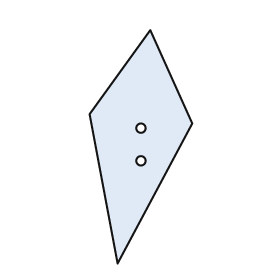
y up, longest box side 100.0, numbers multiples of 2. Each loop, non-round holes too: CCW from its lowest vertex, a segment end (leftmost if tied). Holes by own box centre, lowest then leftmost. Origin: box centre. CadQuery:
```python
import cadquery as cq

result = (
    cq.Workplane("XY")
    .moveTo(-10.0, -50.0)
    .lineTo(22.0, 10.0)
    .lineTo(4.0, 50.0)
    .lineTo(-22.0, 14.0)
    .close()
    .moveTo(0.0, -6.0)
    .circle(2.0)
    .moveTo(0.0, 8.0)
    .circle(2.0)
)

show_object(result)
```